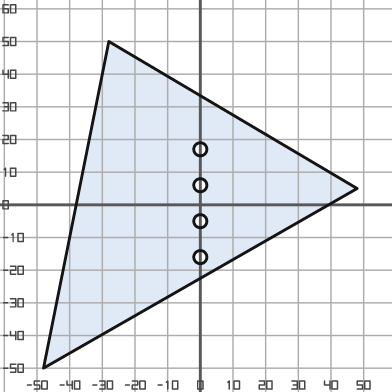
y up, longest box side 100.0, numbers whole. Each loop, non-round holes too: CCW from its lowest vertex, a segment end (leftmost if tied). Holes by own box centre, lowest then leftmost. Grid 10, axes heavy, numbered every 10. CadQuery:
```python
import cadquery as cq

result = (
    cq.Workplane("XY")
    .moveTo(-48.0, -50.0)
    .lineTo(48.0, 5.0)
    .lineTo(-28.0, 50.0)
    .close()
    .moveTo(0.0, -16.0)
    .circle(2.0)
    .moveTo(0.0, -5.0)
    .circle(2.0)
    .moveTo(0.0, 6.0)
    .circle(2.0)
    .moveTo(0.0, 17.0)
    .circle(2.0)
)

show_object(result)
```